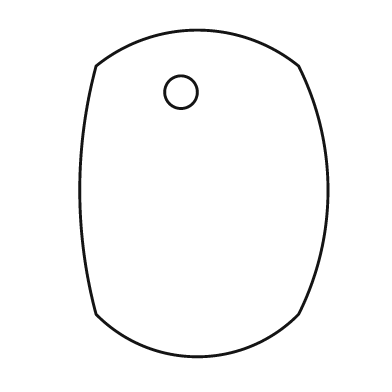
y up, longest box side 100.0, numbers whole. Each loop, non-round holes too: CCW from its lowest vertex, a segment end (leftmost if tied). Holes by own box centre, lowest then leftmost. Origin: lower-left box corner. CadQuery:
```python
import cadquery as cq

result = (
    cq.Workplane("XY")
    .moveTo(5.0, 13.0)
    .threePointArc((36.0, 0.0), (67.0, 13.0))
    .threePointArc((76.0, 51.0), (67.0, 89.0))
    .threePointArc((36.0, 100.0), (5.0, 89.0))
    .threePointArc((0.0, 51.0), (5.0, 13.0))
    .close()
    .moveTo(31.0, 81.0)
    .circle(5.0)
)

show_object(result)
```